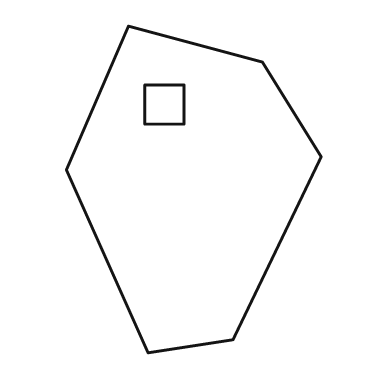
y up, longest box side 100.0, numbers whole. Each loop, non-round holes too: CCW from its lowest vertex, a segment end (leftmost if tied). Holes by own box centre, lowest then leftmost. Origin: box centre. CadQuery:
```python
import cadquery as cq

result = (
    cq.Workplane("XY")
    .moveTo(-14.0, -50.0)
    .lineTo(12.0, -46.0)
    .lineTo(39.0, 10.0)
    .lineTo(21.0, 39.0)
    .lineTo(-20.0, 50.0)
    .lineTo(-39.0, 6.0)
    .close()
    .moveTo(-15.0, 20.0)
    .lineTo(-3.0, 20.0)
    .lineTo(-3.0, 32.0)
    .lineTo(-15.0, 32.0)
    .close()
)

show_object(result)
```